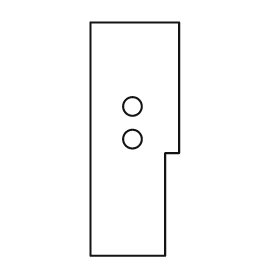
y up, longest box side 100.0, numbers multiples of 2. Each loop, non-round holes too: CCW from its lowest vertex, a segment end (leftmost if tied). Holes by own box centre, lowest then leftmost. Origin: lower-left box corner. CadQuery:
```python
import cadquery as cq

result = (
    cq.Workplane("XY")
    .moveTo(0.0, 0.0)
    .lineTo(32.0, 0.0)
    .lineTo(32.0, 44.0)
    .lineTo(38.0, 44.0)
    .lineTo(38.0, 100.0)
    .lineTo(0.0, 100.0)
    .close()
    .moveTo(18.0, 50.0)
    .circle(4.0)
    .moveTo(18.0, 64.0)
    .circle(4.0)
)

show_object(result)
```